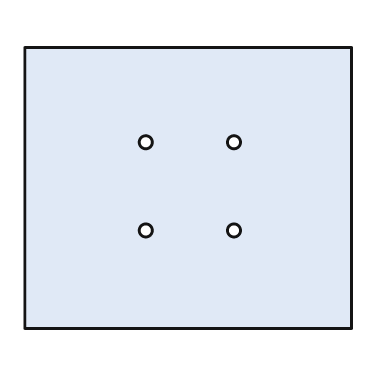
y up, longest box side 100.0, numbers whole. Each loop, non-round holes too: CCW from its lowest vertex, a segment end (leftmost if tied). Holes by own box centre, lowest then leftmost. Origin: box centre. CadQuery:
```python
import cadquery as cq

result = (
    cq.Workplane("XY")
    .moveTo(-50.0, -43.0)
    .lineTo(50.0, -43.0)
    .lineTo(50.0, 43.0)
    .lineTo(-50.0, 43.0)
    .close()
    .moveTo(-13.0, -13.0)
    .circle(2.0)
    .moveTo(14.0, -13.0)
    .circle(2.0)
    .moveTo(-13.0, 14.0)
    .circle(2.0)
    .moveTo(14.0, 14.0)
    .circle(2.0)
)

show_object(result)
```